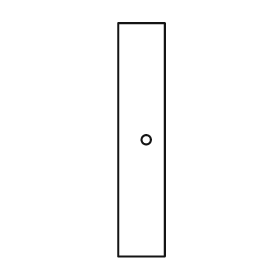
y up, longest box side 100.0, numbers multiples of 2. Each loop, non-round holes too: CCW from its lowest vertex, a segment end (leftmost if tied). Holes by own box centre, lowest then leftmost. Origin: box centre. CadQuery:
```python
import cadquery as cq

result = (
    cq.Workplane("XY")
    .moveTo(-10.0, -50.0)
    .lineTo(10.0, -50.0)
    .lineTo(10.0, 50.0)
    .lineTo(-10.0, 50.0)
    .close()
    .moveTo(2.0, 0.0)
    .circle(2.0)
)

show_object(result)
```